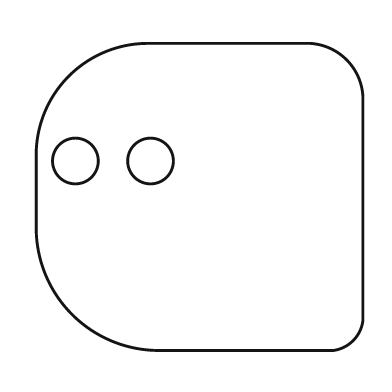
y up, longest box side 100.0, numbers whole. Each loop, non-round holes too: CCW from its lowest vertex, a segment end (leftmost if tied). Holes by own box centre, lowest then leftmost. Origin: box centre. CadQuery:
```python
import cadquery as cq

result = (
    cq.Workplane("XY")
    .moveTo(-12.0, -47.0)
    .lineTo(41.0, -47.0)
    .threePointArc((47.0, -44.0), (50.0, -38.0))
    .lineTo(50.0, 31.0)
    .threePointArc((45.0, 42.0), (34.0, 47.0))
    .lineTo(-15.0, 47.0)
    .threePointArc((-40.0, 37.0), (-50.0, 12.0))
    .lineTo(-50.0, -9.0)
    .threePointArc((-39.0, -36.0), (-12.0, -47.0))
    .close()
    .moveTo(-38.0, 11.0)
    .circle(7.0)
    .moveTo(-15.0, 11.0)
    .circle(7.0)
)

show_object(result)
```